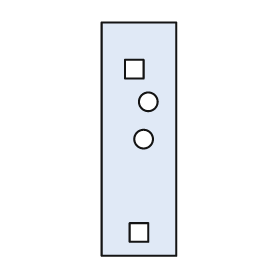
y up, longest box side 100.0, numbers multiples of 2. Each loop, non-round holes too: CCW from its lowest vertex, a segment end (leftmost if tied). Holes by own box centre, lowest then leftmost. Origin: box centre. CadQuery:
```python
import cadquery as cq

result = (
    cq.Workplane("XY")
    .moveTo(-16.0, -50.0)
    .lineTo(16.0, -50.0)
    .lineTo(16.0, 50.0)
    .lineTo(-16.0, 50.0)
    .close()
    .moveTo(-4.0, -44.0)
    .lineTo(4.0, -44.0)
    .lineTo(4.0, -36.0)
    .lineTo(-4.0, -36.0)
    .close()
    .moveTo(2.0, 0.0)
    .circle(4.0)
    .moveTo(4.0, 16.0)
    .circle(4.0)
    .moveTo(-6.0, 26.0)
    .lineTo(2.0, 26.0)
    .lineTo(2.0, 34.0)
    .lineTo(-6.0, 34.0)
    .close()
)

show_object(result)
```